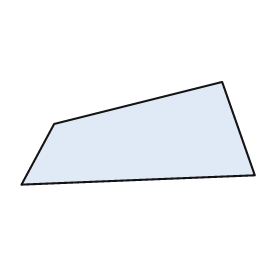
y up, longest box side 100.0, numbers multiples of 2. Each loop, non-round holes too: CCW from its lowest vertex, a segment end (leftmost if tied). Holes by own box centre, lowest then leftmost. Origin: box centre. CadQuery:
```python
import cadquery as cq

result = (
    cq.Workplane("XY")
    .moveTo(-50.0, -22.0)
    .lineTo(50.0, -18.0)
    .lineTo(36.0, 22.0)
    .lineTo(-36.0, 4.0)
    .close()
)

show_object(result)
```